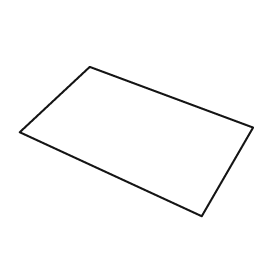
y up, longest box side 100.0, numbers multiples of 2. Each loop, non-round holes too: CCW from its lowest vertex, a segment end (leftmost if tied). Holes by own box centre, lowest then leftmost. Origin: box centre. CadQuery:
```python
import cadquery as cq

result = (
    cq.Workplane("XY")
    .moveTo(28.0, -32.0)
    .lineTo(50.0, 6.0)
    .lineTo(-20.0, 32.0)
    .lineTo(-50.0, 4.0)
    .close()
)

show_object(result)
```